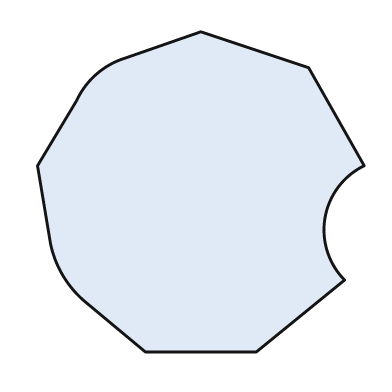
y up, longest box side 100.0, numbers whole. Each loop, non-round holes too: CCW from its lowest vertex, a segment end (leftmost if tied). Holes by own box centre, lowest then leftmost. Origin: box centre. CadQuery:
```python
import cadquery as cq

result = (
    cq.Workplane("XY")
    .moveTo(-17.0, -49.0)
    .lineTo(17.0, -49.0)
    .lineTo(44.0, -27.0)
    .threePointArc((38.0, -8.0), (50.0, 8.0))
    .lineTo(33.0, 38.0)
    .lineTo(0.0, 49.0)
    .lineTo(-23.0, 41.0)
    .threePointArc((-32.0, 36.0), (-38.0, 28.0))
    .lineTo(-50.0, 8.0)
    .lineTo(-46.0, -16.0)
    .threePointArc((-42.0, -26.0), (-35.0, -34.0))
    .close()
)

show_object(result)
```